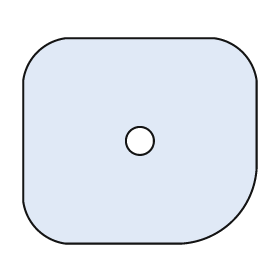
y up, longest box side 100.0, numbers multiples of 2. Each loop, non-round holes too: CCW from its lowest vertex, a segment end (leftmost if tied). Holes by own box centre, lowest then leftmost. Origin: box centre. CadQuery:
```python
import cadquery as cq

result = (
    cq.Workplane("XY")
    .moveTo(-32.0, -44.0)
    .lineTo(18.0, -44.0)
    .threePointArc((40.0, -34.0), (50.0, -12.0))
    .lineTo(50.0, 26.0)
    .threePointArc((44.0, 38.0), (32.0, 44.0))
    .lineTo(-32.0, 44.0)
    .threePointArc((-44.0, 38.0), (-50.0, 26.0))
    .lineTo(-50.0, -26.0)
    .threePointArc((-44.0, -38.0), (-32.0, -44.0))
    .close()
    .moveTo(0.0, 0.0)
    .circle(6.0)
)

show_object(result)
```